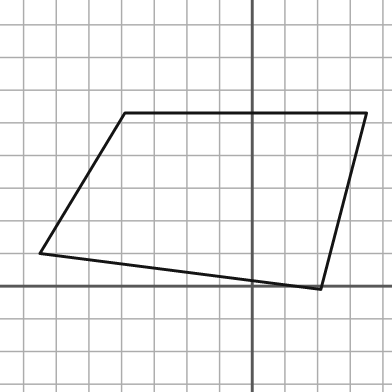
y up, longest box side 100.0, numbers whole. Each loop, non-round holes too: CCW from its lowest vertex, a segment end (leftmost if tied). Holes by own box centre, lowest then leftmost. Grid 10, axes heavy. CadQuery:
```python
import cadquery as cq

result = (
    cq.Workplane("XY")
    .moveTo(21.0, -1.0)
    .lineTo(35.0, 53.0)
    .lineTo(-39.0, 53.0)
    .lineTo(-65.0, 10.0)
    .close()
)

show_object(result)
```